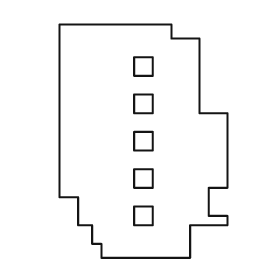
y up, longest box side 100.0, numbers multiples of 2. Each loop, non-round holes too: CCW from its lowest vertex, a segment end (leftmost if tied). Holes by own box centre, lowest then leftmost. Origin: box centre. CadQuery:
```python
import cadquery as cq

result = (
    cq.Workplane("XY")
    .moveTo(-18.0, -50.0)
    .lineTo(20.0, -50.0)
    .lineTo(20.0, -36.0)
    .lineTo(36.0, -36.0)
    .lineTo(36.0, -32.0)
    .lineTo(28.0, -32.0)
    .lineTo(28.0, -20.0)
    .lineTo(36.0, -20.0)
    .lineTo(36.0, 12.0)
    .lineTo(24.0, 12.0)
    .lineTo(24.0, 44.0)
    .lineTo(12.0, 44.0)
    .lineTo(12.0, 50.0)
    .lineTo(-36.0, 50.0)
    .lineTo(-36.0, -24.0)
    .lineTo(-28.0, -24.0)
    .lineTo(-28.0, -36.0)
    .lineTo(-22.0, -36.0)
    .lineTo(-22.0, -44.0)
    .lineTo(-18.0, -44.0)
    .close()
    .moveTo(-4.0, -36.0)
    .lineTo(4.0, -36.0)
    .lineTo(4.0, -28.0)
    .lineTo(-4.0, -28.0)
    .close()
    .moveTo(-4.0, -20.0)
    .lineTo(4.0, -20.0)
    .lineTo(4.0, -12.0)
    .lineTo(-4.0, -12.0)
    .close()
    .moveTo(-4.0, -4.0)
    .lineTo(4.0, -4.0)
    .lineTo(4.0, 4.0)
    .lineTo(-4.0, 4.0)
    .close()
    .moveTo(-4.0, 12.0)
    .lineTo(4.0, 12.0)
    .lineTo(4.0, 20.0)
    .lineTo(-4.0, 20.0)
    .close()
    .moveTo(-4.0, 28.0)
    .lineTo(4.0, 28.0)
    .lineTo(4.0, 36.0)
    .lineTo(-4.0, 36.0)
    .close()
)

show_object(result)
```